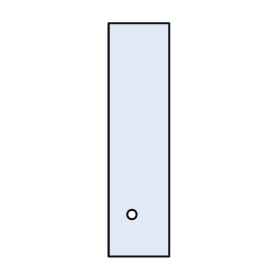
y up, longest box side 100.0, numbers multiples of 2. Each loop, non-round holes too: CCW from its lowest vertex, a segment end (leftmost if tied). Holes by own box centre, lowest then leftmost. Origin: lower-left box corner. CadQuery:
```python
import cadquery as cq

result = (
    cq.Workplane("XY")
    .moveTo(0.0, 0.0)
    .lineTo(26.0, 0.0)
    .lineTo(26.0, 100.0)
    .lineTo(0.0, 100.0)
    .close()
    .moveTo(10.0, 18.0)
    .circle(2.0)
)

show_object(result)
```